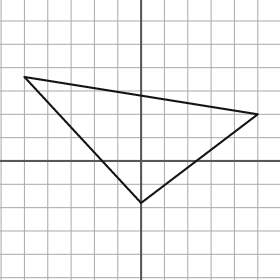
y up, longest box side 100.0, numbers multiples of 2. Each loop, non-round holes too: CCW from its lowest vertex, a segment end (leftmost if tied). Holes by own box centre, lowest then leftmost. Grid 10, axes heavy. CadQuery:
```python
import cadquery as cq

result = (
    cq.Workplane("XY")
    .moveTo(0.0, -18.0)
    .lineTo(50.0, 20.0)
    .lineTo(-50.0, 36.0)
    .close()
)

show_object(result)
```